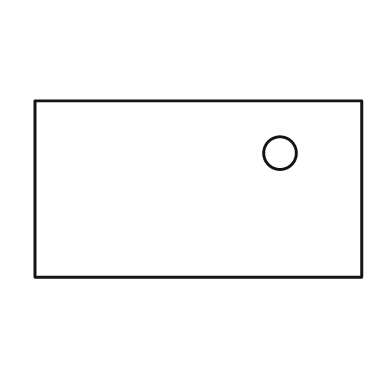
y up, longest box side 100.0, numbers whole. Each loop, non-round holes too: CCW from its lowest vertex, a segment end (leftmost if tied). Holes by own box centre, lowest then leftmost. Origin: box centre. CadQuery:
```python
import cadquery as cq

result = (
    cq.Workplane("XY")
    .moveTo(-50.0, -27.0)
    .lineTo(50.0, -27.0)
    .lineTo(50.0, 27.0)
    .lineTo(-50.0, 27.0)
    .close()
    .moveTo(25.0, 11.0)
    .circle(5.0)
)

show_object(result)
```